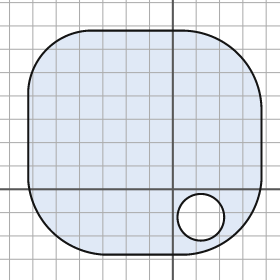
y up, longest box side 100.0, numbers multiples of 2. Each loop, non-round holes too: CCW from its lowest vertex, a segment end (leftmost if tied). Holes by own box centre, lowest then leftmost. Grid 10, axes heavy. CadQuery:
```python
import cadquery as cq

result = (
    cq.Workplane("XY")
    .moveTo(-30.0, -28.0)
    .lineTo(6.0, -28.0)
    .threePointArc((28.0, -18.0), (38.0, 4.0))
    .lineTo(38.0, 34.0)
    .threePointArc((28.0, 58.0), (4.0, 68.0))
    .lineTo(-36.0, 68.0)
    .threePointArc((-54.0, 60.0), (-62.0, 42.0))
    .lineTo(-62.0, 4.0)
    .threePointArc((-52.0, -18.0), (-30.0, -28.0))
    .close()
    .moveTo(12.0, -12.0)
    .circle(10.0)
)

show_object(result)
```